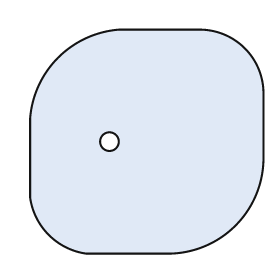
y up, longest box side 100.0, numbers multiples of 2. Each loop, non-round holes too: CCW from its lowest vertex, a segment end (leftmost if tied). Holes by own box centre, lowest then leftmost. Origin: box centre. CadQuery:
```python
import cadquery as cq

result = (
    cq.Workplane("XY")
    .moveTo(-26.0, -48.0)
    .lineTo(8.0, -48.0)
    .threePointArc((38.0, -36.0), (50.0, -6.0))
    .lineTo(50.0, 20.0)
    .threePointArc((42.0, 40.0), (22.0, 48.0))
    .lineTo(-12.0, 48.0)
    .threePointArc((-38.0, 36.0), (-50.0, 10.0))
    .lineTo(-50.0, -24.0)
    .threePointArc((-42.0, -40.0), (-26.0, -48.0))
    .close()
    .moveTo(-16.0, 0.0)
    .circle(4.0)
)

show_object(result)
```